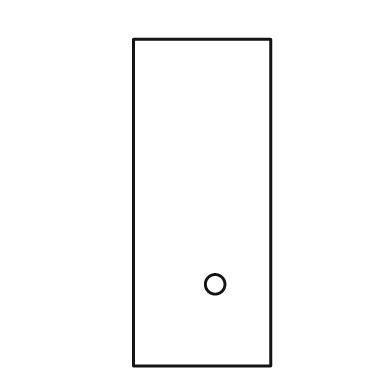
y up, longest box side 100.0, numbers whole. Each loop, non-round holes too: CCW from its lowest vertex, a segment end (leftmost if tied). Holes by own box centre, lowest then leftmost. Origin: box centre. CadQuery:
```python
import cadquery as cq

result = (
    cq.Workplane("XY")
    .moveTo(-21.0, -50.0)
    .lineTo(21.0, -50.0)
    .lineTo(21.0, 50.0)
    .lineTo(-21.0, 50.0)
    .close()
    .moveTo(4.0, -25.0)
    .circle(3.0)
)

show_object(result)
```